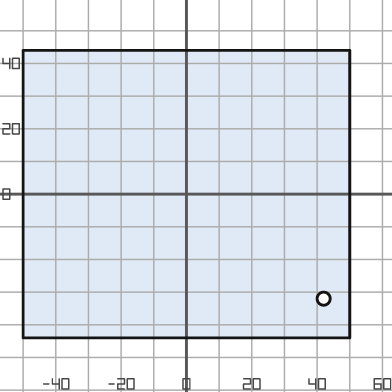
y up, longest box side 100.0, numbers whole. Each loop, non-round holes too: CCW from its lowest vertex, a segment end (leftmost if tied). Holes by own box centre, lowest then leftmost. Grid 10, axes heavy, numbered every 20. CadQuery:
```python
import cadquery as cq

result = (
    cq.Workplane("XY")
    .moveTo(-50.0, -44.0)
    .lineTo(50.0, -44.0)
    .lineTo(50.0, 44.0)
    .lineTo(-50.0, 44.0)
    .close()
    .moveTo(42.0, -32.0)
    .circle(2.0)
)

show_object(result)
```